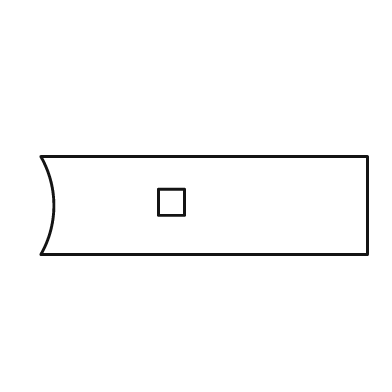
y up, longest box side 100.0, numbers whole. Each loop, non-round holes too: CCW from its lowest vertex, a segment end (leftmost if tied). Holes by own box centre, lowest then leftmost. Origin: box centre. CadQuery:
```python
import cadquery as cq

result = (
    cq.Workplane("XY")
    .moveTo(-50.0, -15.0)
    .lineTo(50.0, -15.0)
    .lineTo(50.0, 15.0)
    .lineTo(-50.0, 15.0)
    .threePointArc((-46.0, 0.0), (-50.0, -15.0))
    .close()
    .moveTo(-14.0, -3.0)
    .lineTo(-6.0, -3.0)
    .lineTo(-6.0, 5.0)
    .lineTo(-14.0, 5.0)
    .close()
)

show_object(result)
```